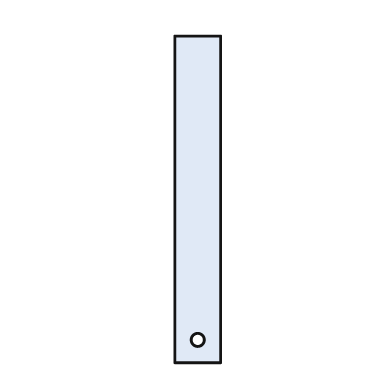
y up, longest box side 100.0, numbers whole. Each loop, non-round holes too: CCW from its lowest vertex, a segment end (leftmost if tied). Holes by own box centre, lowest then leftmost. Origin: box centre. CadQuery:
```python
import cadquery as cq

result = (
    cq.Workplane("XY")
    .moveTo(-7.0, -50.0)
    .lineTo(7.0, -50.0)
    .lineTo(7.0, 50.0)
    .lineTo(-7.0, 50.0)
    .close()
    .moveTo(0.0, -43.0)
    .circle(2.0)
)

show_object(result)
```